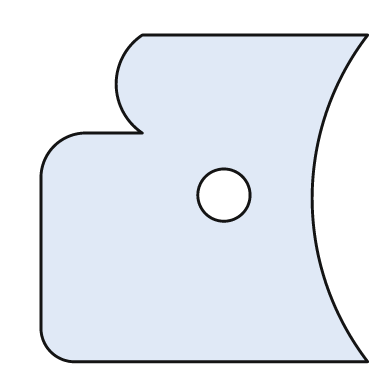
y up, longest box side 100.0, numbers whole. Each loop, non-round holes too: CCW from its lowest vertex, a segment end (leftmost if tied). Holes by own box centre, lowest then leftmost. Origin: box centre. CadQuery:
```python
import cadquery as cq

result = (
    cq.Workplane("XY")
    .moveTo(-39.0, -50.0)
    .lineTo(50.0, -50.0)
    .threePointArc((33.0, 0.0), (50.0, 50.0))
    .lineTo(-19.0, 50.0)
    .threePointArc((-27.0, 35.0), (-19.0, 20.0))
    .lineTo(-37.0, 20.0)
    .threePointArc((-46.0, 16.0), (-50.0, 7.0))
    .lineTo(-50.0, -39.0)
    .threePointArc((-47.0, -47.0), (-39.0, -50.0))
    .close()
    .moveTo(6.0, 1.0)
    .circle(8.0)
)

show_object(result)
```